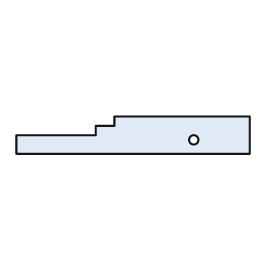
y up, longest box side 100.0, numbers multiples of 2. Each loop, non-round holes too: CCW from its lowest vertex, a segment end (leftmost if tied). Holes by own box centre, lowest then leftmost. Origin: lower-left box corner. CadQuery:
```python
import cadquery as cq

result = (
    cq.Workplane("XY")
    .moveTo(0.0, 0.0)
    .lineTo(100.0, 0.0)
    .lineTo(100.0, 16.0)
    .lineTo(42.0, 16.0)
    .lineTo(42.0, 12.0)
    .lineTo(34.0, 12.0)
    .lineTo(34.0, 8.0)
    .lineTo(0.0, 8.0)
    .close()
    .moveTo(76.0, 6.0)
    .circle(2.0)
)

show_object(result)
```